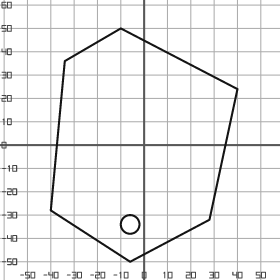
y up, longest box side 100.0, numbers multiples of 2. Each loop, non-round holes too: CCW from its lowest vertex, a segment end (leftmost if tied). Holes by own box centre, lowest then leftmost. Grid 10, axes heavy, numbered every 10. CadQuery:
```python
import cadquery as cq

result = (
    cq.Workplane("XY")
    .moveTo(-6.0, -50.0)
    .lineTo(28.0, -32.0)
    .lineTo(40.0, 24.0)
    .lineTo(-10.0, 50.0)
    .lineTo(-34.0, 36.0)
    .lineTo(-40.0, -28.0)
    .close()
    .moveTo(-6.0, -34.0)
    .circle(4.0)
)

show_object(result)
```